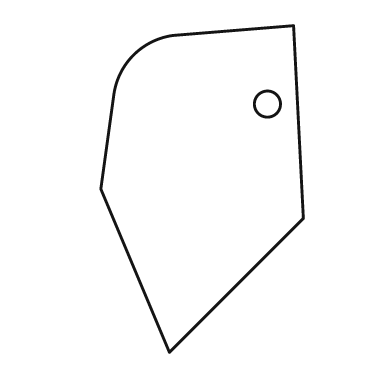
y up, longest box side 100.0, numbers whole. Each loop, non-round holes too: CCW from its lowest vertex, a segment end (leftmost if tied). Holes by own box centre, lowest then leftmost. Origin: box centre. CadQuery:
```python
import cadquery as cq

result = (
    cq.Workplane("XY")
    .moveTo(-10.0, -50.0)
    .lineTo(31.0, -9.0)
    .lineTo(28.0, 50.0)
    .lineTo(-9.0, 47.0)
    .threePointArc((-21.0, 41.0), (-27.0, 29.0))
    .lineTo(-31.0, 0.0)
    .close()
    .moveTo(20.0, 26.0)
    .circle(4.0)
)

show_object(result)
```